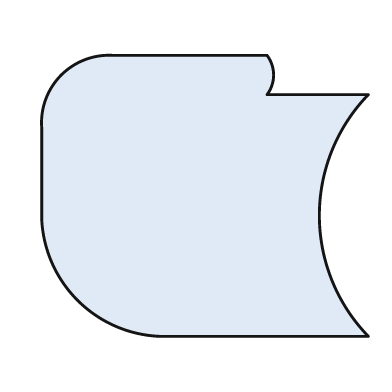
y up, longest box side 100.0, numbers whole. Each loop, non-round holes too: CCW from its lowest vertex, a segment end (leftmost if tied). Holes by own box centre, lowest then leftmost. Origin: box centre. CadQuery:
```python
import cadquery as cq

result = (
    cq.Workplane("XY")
    .moveTo(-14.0, -43.0)
    .lineTo(50.0, -43.0)
    .threePointArc((35.0, -6.0), (50.0, 31.0))
    .lineTo(19.0, 31.0)
    .threePointArc((21.0, 37.0), (19.0, 43.0))
    .lineTo(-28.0, 43.0)
    .threePointArc((-44.0, 37.0), (-50.0, 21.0))
    .lineTo(-50.0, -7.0)
    .threePointArc((-39.0, -32.0), (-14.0, -43.0))
    .close()
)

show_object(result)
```